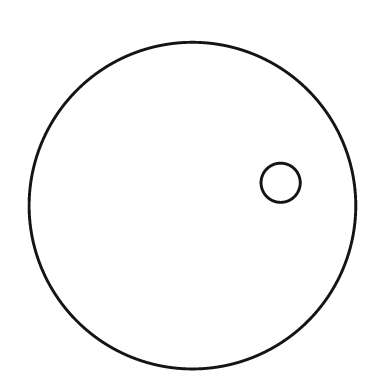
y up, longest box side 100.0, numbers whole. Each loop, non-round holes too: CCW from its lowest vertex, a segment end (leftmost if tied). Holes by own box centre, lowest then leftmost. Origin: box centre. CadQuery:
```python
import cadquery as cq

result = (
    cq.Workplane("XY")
    .moveTo(0.0, 0.0)
    .circle(50.0)
    .moveTo(27.0, 7.0)
    .circle(6.0)
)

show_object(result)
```